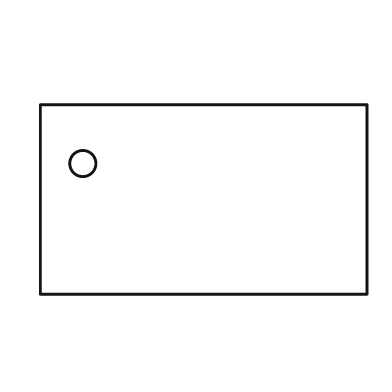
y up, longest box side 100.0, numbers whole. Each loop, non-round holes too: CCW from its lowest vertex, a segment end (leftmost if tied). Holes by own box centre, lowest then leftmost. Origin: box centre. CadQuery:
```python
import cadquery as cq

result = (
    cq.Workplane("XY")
    .moveTo(-50.0, -29.0)
    .lineTo(50.0, -29.0)
    .lineTo(50.0, 29.0)
    .lineTo(-50.0, 29.0)
    .close()
    .moveTo(-37.0, 11.0)
    .circle(4.0)
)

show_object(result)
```